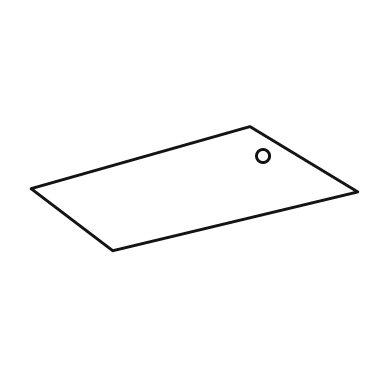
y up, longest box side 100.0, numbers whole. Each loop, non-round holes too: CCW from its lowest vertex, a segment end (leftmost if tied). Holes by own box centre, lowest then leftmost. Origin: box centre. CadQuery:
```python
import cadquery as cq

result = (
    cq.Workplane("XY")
    .moveTo(-25.0, -19.0)
    .lineTo(50.0, -1.0)
    .lineTo(17.0, 19.0)
    .lineTo(-50.0, 0.0)
    .close()
    .moveTo(21.0, 10.0)
    .circle(2.0)
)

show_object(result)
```